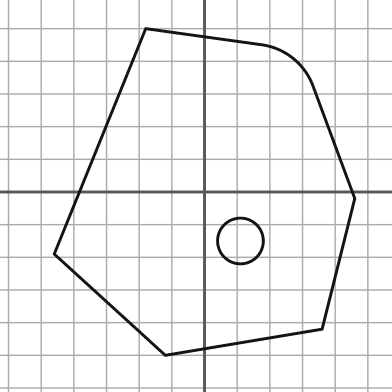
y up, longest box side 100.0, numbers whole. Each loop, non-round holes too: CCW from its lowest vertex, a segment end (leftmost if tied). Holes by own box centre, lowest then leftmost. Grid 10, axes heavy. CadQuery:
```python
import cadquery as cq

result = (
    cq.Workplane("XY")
    .moveTo(-12.0, -50.0)
    .lineTo(36.0, -42.0)
    .lineTo(46.0, -2.0)
    .lineTo(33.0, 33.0)
    .threePointArc((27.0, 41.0), (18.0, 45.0))
    .lineTo(-18.0, 50.0)
    .lineTo(-46.0, -19.0)
    .close()
    .moveTo(11.0, -15.0)
    .circle(7.0)
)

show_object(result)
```